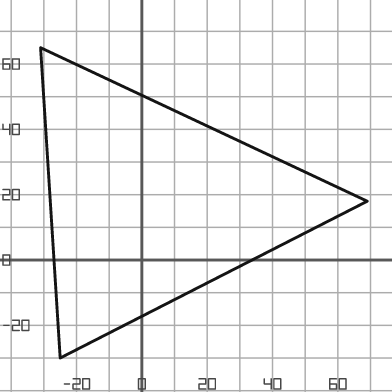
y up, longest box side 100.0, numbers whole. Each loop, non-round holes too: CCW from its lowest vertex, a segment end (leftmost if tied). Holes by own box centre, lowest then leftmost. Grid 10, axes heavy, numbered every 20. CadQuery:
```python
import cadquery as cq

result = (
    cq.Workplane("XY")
    .moveTo(-25.0, -30.0)
    .lineTo(69.0, 18.0)
    .lineTo(-31.0, 65.0)
    .close()
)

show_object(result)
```